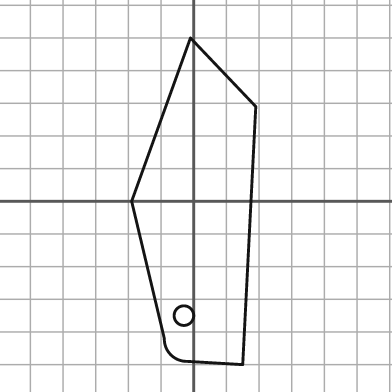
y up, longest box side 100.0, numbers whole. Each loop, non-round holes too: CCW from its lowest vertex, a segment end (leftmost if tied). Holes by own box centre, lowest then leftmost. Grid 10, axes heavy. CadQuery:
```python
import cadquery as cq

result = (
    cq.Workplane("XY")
    .moveTo(15.0, -50.0)
    .lineTo(19.0, 29.0)
    .lineTo(-1.0, 50.0)
    .lineTo(-19.0, 0.0)
    .lineTo(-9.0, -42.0)
    .threePointArc((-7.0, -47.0), (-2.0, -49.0))
    .close()
    .moveTo(-3.0, -35.0)
    .circle(3.0)
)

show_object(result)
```